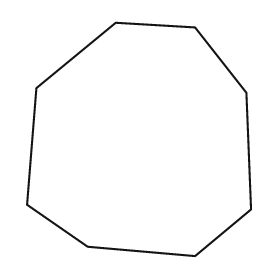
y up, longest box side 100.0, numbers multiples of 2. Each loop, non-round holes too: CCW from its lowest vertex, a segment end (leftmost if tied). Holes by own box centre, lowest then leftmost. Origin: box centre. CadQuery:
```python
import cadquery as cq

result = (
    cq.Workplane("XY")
    .moveTo(24.0, -50.0)
    .lineTo(48.0, -30.0)
    .lineTo(46.0, 20.0)
    .lineTo(24.0, 48.0)
    .lineTo(-10.0, 50.0)
    .lineTo(-44.0, 22.0)
    .lineTo(-48.0, -28.0)
    .lineTo(-22.0, -46.0)
    .close()
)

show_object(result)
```